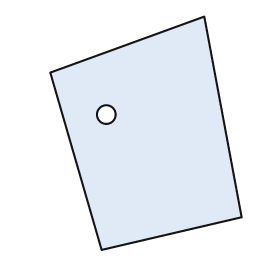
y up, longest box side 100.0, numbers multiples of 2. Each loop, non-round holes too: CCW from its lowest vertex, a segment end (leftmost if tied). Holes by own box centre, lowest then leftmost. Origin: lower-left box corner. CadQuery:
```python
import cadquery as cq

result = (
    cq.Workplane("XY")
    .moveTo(22.0, 0.0)
    .lineTo(82.0, 14.0)
    .lineTo(66.0, 100.0)
    .lineTo(0.0, 76.0)
    .close()
    .moveTo(24.0, 58.0)
    .circle(4.0)
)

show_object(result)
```